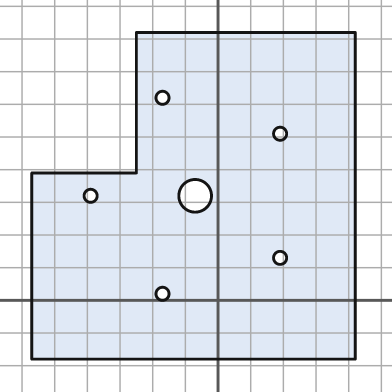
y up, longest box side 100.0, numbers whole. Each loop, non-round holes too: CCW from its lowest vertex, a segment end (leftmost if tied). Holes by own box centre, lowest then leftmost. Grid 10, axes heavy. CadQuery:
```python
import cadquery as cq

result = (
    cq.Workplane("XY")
    .moveTo(-57.0, -18.0)
    .lineTo(42.0, -18.0)
    .lineTo(42.0, 82.0)
    .lineTo(-25.0, 82.0)
    .lineTo(-25.0, 39.0)
    .lineTo(-57.0, 39.0)
    .close()
    .moveTo(-17.0, 2.0)
    .circle(2.0)
    .moveTo(19.0, 13.0)
    .circle(2.0)
    .moveTo(-39.0, 32.0)
    .circle(2.0)
    .moveTo(-7.0, 32.0)
    .circle(5.0)
    .moveTo(19.0, 51.0)
    .circle(2.0)
    .moveTo(-17.0, 62.0)
    .circle(2.0)
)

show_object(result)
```